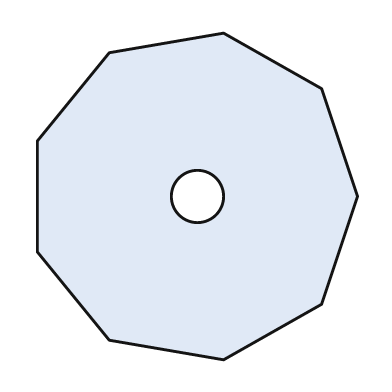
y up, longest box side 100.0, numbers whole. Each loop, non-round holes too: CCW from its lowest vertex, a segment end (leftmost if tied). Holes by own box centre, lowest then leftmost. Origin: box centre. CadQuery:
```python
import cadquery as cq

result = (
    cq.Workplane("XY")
    .moveTo(8.0, -50.0)
    .lineTo(38.0, -33.0)
    .lineTo(49.0, 0.0)
    .lineTo(38.0, 33.0)
    .lineTo(8.0, 50.0)
    .lineTo(-27.0, 44.0)
    .lineTo(-49.0, 17.0)
    .lineTo(-49.0, -17.0)
    .lineTo(-27.0, -44.0)
    .close()
    .moveTo(0.0, 0.0)
    .circle(8.0)
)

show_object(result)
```